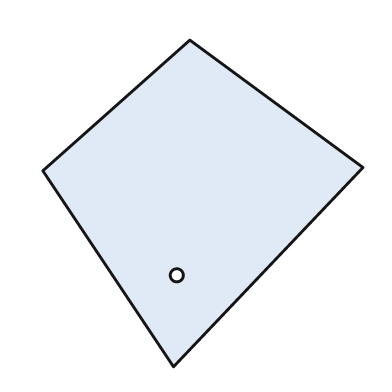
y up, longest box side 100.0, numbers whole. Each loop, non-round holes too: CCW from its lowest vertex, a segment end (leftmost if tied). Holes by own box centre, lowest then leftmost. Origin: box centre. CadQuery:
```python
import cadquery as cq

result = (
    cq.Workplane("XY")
    .moveTo(-9.0, -50.0)
    .lineTo(49.0, 11.0)
    .lineTo(-4.0, 50.0)
    .lineTo(-49.0, 10.0)
    .close()
    .moveTo(-8.0, -22.0)
    .circle(2.0)
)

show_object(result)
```